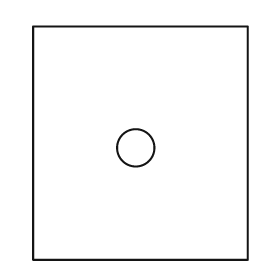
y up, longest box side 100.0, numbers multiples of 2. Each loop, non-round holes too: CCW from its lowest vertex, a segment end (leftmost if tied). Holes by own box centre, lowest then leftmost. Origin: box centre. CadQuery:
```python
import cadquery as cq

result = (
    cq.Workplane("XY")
    .moveTo(-46.0, -50.0)
    .lineTo(46.0, -50.0)
    .lineTo(46.0, 50.0)
    .lineTo(-46.0, 50.0)
    .close()
    .moveTo(-2.0, -2.0)
    .circle(8.0)
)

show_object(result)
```